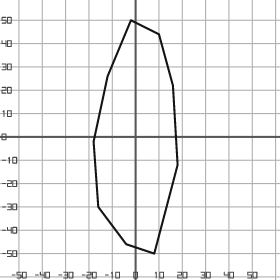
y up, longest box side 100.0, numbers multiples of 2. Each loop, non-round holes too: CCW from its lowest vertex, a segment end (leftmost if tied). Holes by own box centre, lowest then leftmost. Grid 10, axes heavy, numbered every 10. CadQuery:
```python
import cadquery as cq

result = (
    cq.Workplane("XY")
    .moveTo(8.0, -50.0)
    .lineTo(18.0, -12.0)
    .lineTo(16.0, 22.0)
    .lineTo(10.0, 44.0)
    .lineTo(-2.0, 50.0)
    .lineTo(-12.0, 26.0)
    .lineTo(-18.0, -2.0)
    .lineTo(-16.0, -30.0)
    .lineTo(-4.0, -46.0)
    .close()
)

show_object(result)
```